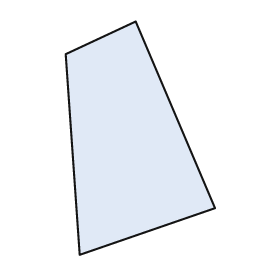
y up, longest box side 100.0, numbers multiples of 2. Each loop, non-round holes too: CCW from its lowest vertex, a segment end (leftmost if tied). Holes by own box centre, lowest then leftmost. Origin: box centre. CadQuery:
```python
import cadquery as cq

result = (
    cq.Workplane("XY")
    .moveTo(-26.0, -50.0)
    .lineTo(32.0, -30.0)
    .lineTo(-2.0, 50.0)
    .lineTo(-32.0, 36.0)
    .close()
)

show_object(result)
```